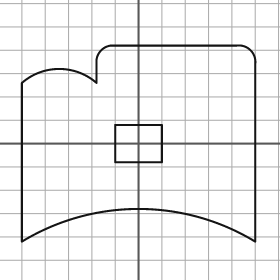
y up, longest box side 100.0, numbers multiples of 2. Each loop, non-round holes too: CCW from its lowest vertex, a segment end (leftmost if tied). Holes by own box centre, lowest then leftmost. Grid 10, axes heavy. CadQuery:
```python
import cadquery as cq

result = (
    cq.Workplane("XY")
    .moveTo(-50.0, -42.0)
    .threePointArc((0.0, -28.0), (50.0, -42.0))
    .lineTo(50.0, 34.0)
    .threePointArc((48.0, 40.0), (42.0, 42.0))
    .lineTo(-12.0, 42.0)
    .threePointArc((-16.0, 40.0), (-18.0, 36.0))
    .lineTo(-18.0, 26.0)
    .threePointArc((-34.0, 32.0), (-50.0, 26.0))
    .close()
    .moveTo(-10.0, -8.0)
    .lineTo(10.0, -8.0)
    .lineTo(10.0, 8.0)
    .lineTo(-10.0, 8.0)
    .close()
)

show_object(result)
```